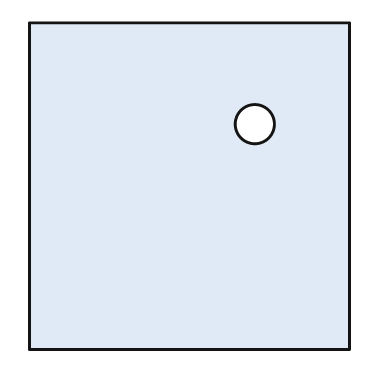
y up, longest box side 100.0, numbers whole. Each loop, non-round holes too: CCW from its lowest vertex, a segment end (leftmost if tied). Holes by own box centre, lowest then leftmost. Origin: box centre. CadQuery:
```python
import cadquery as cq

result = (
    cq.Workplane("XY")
    .moveTo(-49.0, -50.0)
    .lineTo(49.0, -50.0)
    .lineTo(49.0, 50.0)
    .lineTo(-49.0, 50.0)
    .close()
    .moveTo(20.0, 19.0)
    .circle(6.0)
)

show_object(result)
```